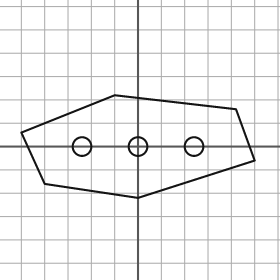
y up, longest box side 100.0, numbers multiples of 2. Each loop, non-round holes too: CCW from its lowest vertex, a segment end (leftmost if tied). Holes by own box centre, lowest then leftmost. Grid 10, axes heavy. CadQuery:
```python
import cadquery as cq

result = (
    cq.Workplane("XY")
    .moveTo(0.0, -22.0)
    .lineTo(50.0, -6.0)
    .lineTo(42.0, 16.0)
    .lineTo(-10.0, 22.0)
    .lineTo(-50.0, 6.0)
    .lineTo(-40.0, -16.0)
    .close()
    .moveTo(-24.0, 0.0)
    .circle(4.0)
    .moveTo(0.0, 0.0)
    .circle(4.0)
    .moveTo(24.0, 0.0)
    .circle(4.0)
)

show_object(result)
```